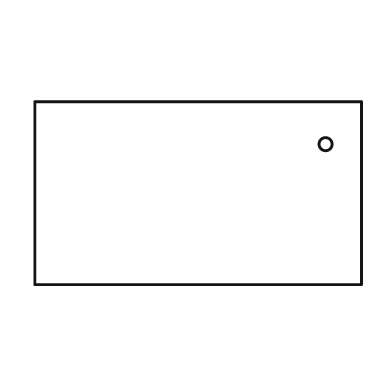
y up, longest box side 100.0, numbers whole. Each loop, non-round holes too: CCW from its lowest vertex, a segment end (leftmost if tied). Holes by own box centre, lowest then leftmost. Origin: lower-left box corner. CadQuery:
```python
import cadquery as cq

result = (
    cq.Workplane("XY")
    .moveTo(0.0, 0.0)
    .lineTo(100.0, 0.0)
    .lineTo(100.0, 56.0)
    .lineTo(0.0, 56.0)
    .close()
    .moveTo(89.0, 43.0)
    .circle(2.0)
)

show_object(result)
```